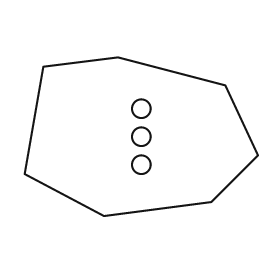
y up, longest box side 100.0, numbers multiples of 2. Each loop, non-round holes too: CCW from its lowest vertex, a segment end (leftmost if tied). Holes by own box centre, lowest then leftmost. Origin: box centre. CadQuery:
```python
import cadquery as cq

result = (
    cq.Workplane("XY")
    .moveTo(-16.0, -34.0)
    .lineTo(30.0, -28.0)
    .lineTo(50.0, -8.0)
    .lineTo(36.0, 22.0)
    .lineTo(-10.0, 34.0)
    .lineTo(-42.0, 30.0)
    .lineTo(-50.0, -16.0)
    .close()
    .moveTo(0.0, -12.0)
    .circle(4.0)
    .moveTo(0.0, 0.0)
    .circle(4.0)
    .moveTo(0.0, 12.0)
    .circle(4.0)
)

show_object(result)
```